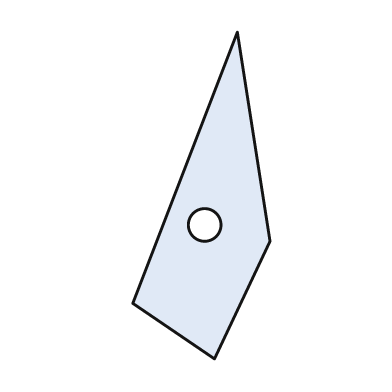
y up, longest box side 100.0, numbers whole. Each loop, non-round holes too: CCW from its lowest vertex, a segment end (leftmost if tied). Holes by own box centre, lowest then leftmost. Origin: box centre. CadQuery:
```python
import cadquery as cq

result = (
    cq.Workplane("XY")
    .moveTo(4.0, -50.0)
    .lineTo(21.0, -14.0)
    .lineTo(11.0, 50.0)
    .lineTo(-21.0, -33.0)
    .close()
    .moveTo(1.0, -9.0)
    .circle(5.0)
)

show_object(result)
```